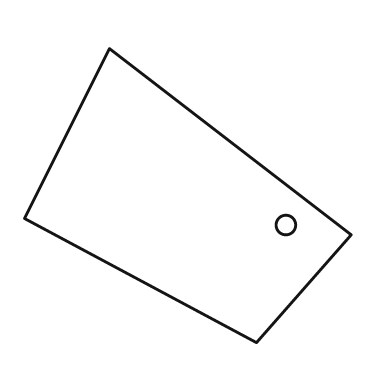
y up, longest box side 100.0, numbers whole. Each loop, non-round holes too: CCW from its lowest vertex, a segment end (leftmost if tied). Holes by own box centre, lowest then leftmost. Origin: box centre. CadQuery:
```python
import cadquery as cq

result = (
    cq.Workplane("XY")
    .moveTo(21.0, -45.0)
    .lineTo(50.0, -12.0)
    .lineTo(-24.0, 45.0)
    .lineTo(-50.0, -7.0)
    .close()
    .moveTo(30.0, -9.0)
    .circle(3.0)
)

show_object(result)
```